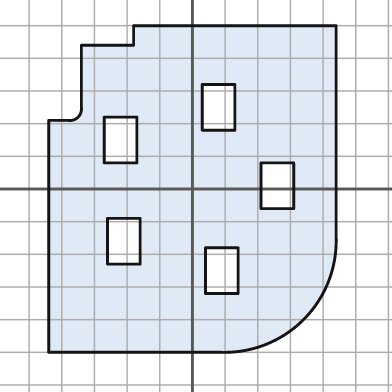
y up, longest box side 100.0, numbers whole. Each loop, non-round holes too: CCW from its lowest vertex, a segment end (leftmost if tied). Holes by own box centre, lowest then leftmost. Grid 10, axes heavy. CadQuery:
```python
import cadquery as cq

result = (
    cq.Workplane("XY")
    .moveTo(-44.0, -50.0)
    .lineTo(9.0, -50.0)
    .threePointArc((34.0, -40.0), (44.0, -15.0))
    .lineTo(44.0, 50.0)
    .lineTo(-18.0, 50.0)
    .lineTo(-18.0, 44.0)
    .lineTo(-34.0, 44.0)
    .lineTo(-34.0, 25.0)
    .threePointArc((-35.0, 22.0), (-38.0, 21.0))
    .lineTo(-44.0, 21.0)
    .close()
    .moveTo(4.0, -32.0)
    .lineTo(14.0, -32.0)
    .lineTo(14.0, -18.0)
    .lineTo(4.0, -18.0)
    .close()
    .moveTo(-26.0, -23.0)
    .lineTo(-16.0, -23.0)
    .lineTo(-16.0, -9.0)
    .lineTo(-26.0, -9.0)
    .close()
    .moveTo(21.0, -6.0)
    .lineTo(31.0, -6.0)
    .lineTo(31.0, 8.0)
    .lineTo(21.0, 8.0)
    .close()
    .moveTo(-27.0, 8.0)
    .lineTo(-17.0, 8.0)
    .lineTo(-17.0, 22.0)
    .lineTo(-27.0, 22.0)
    .close()
    .moveTo(3.0, 18.0)
    .lineTo(13.0, 18.0)
    .lineTo(13.0, 32.0)
    .lineTo(3.0, 32.0)
    .close()
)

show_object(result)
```